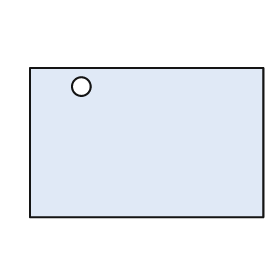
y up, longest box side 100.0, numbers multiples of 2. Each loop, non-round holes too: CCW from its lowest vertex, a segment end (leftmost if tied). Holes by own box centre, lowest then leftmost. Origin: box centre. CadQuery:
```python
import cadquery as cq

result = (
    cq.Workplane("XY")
    .moveTo(-50.0, -32.0)
    .lineTo(50.0, -32.0)
    .lineTo(50.0, 32.0)
    .lineTo(-50.0, 32.0)
    .close()
    .moveTo(-28.0, 24.0)
    .circle(4.0)
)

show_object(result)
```